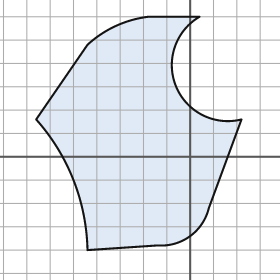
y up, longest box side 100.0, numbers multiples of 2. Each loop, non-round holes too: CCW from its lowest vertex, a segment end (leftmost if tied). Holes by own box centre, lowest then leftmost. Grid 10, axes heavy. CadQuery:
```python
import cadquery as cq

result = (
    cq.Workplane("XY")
    .moveTo(-44.0, -40.0)
    .lineTo(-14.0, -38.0)
    .threePointArc((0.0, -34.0), (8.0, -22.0))
    .lineTo(22.0, 16.0)
    .threePointArc((-6.0, 30.0), (4.0, 60.0))
    .lineTo(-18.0, 60.0)
    .threePointArc((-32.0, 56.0), (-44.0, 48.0))
    .lineTo(-66.0, 16.0)
    .threePointArc((-50.0, -10.0), (-44.0, -40.0))
    .close()
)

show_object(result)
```